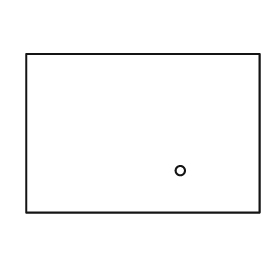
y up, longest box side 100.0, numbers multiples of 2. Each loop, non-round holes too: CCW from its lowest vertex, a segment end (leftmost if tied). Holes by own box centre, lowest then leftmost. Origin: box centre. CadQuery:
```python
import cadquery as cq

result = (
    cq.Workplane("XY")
    .moveTo(-50.0, -34.0)
    .lineTo(50.0, -34.0)
    .lineTo(50.0, 34.0)
    .lineTo(-50.0, 34.0)
    .close()
    .moveTo(16.0, -16.0)
    .circle(2.0)
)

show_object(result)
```